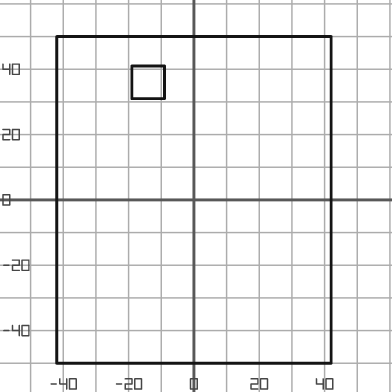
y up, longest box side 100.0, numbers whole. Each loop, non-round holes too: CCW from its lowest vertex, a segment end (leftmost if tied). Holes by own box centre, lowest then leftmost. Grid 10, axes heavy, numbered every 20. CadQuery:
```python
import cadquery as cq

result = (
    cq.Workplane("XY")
    .moveTo(-42.0, -50.0)
    .lineTo(42.0, -50.0)
    .lineTo(42.0, 50.0)
    .lineTo(-42.0, 50.0)
    .close()
    .moveTo(-19.0, 31.0)
    .lineTo(-9.0, 31.0)
    .lineTo(-9.0, 41.0)
    .lineTo(-19.0, 41.0)
    .close()
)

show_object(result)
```